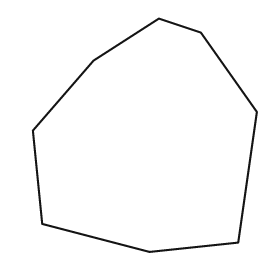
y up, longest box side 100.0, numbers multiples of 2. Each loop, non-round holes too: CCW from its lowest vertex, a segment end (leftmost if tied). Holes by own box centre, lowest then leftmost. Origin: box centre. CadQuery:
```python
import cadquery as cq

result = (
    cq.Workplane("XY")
    .moveTo(2.0, -50.0)
    .lineTo(40.0, -46.0)
    .lineTo(48.0, 10.0)
    .lineTo(24.0, 44.0)
    .lineTo(6.0, 50.0)
    .lineTo(-22.0, 32.0)
    .lineTo(-48.0, 2.0)
    .lineTo(-44.0, -38.0)
    .close()
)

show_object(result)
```